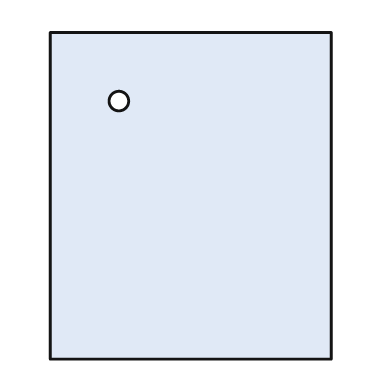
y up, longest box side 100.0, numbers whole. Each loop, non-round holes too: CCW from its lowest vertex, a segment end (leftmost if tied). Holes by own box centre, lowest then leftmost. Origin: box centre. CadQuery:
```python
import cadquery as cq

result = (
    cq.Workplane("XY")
    .moveTo(-43.0, -50.0)
    .lineTo(43.0, -50.0)
    .lineTo(43.0, 50.0)
    .lineTo(-43.0, 50.0)
    .close()
    .moveTo(-22.0, 29.0)
    .circle(3.0)
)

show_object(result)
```